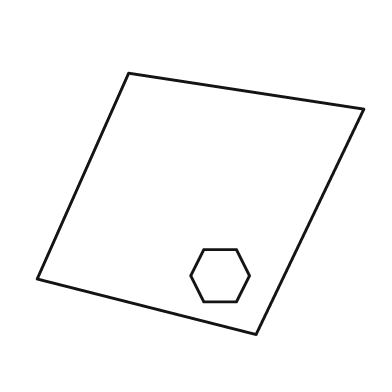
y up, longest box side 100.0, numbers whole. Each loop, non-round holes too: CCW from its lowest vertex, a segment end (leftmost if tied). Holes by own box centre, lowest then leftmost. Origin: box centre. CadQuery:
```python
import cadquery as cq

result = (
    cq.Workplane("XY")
    .moveTo(17.0, -40.0)
    .lineTo(50.0, 29.0)
    .lineTo(-22.0, 40.0)
    .lineTo(-50.0, -23.0)
    .close()
    .moveTo(1.0, -30.0)
    .lineTo(11.0, -30.0)
    .lineTo(15.0, -22.0)
    .lineTo(11.0, -14.0)
    .lineTo(1.0, -14.0)
    .lineTo(-3.0, -22.0)
    .close()
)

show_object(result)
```